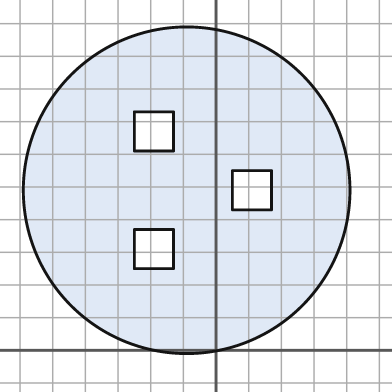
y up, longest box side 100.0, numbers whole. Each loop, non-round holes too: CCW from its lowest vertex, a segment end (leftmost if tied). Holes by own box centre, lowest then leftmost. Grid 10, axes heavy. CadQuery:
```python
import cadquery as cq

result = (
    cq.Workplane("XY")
    .moveTo(-9.0, 49.0)
    .circle(50.0)
    .moveTo(-25.0, 25.0)
    .lineTo(-13.0, 25.0)
    .lineTo(-13.0, 37.0)
    .lineTo(-25.0, 37.0)
    .close()
    .moveTo(5.0, 43.0)
    .lineTo(17.0, 43.0)
    .lineTo(17.0, 55.0)
    .lineTo(5.0, 55.0)
    .close()
    .moveTo(-25.0, 61.0)
    .lineTo(-13.0, 61.0)
    .lineTo(-13.0, 73.0)
    .lineTo(-25.0, 73.0)
    .close()
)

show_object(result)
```